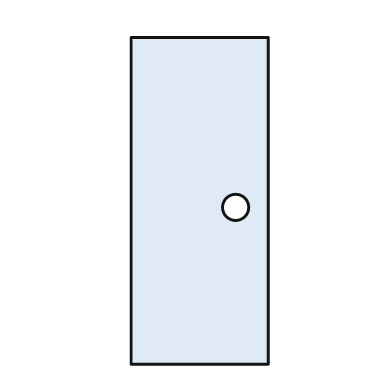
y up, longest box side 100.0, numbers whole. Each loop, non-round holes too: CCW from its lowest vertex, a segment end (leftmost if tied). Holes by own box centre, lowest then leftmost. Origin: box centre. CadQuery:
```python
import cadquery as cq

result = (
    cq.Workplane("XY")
    .moveTo(-21.0, -50.0)
    .lineTo(21.0, -50.0)
    .lineTo(21.0, 50.0)
    .lineTo(-21.0, 50.0)
    .close()
    .moveTo(11.0, -2.0)
    .circle(4.0)
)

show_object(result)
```